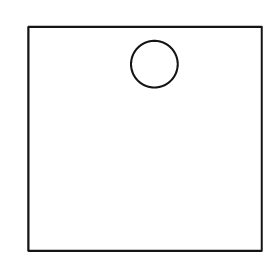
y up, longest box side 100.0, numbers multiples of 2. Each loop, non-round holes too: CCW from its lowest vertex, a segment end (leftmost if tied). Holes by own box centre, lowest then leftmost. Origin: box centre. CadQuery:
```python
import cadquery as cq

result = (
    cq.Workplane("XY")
    .moveTo(-50.0, -48.0)
    .lineTo(50.0, -48.0)
    .lineTo(50.0, 48.0)
    .lineTo(-50.0, 48.0)
    .close()
    .moveTo(4.0, 32.0)
    .circle(10.0)
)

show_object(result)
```